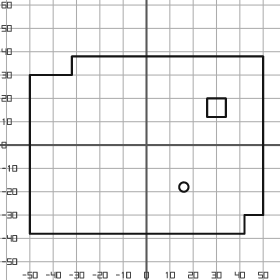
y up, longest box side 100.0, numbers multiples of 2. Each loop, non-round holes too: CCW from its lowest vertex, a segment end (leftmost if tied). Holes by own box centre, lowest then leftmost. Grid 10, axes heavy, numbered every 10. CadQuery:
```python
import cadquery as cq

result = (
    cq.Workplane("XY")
    .moveTo(-50.0, -38.0)
    .lineTo(42.0, -38.0)
    .lineTo(42.0, -30.0)
    .lineTo(50.0, -30.0)
    .lineTo(50.0, 38.0)
    .lineTo(-32.0, 38.0)
    .lineTo(-32.0, 30.0)
    .lineTo(-50.0, 30.0)
    .close()
    .moveTo(16.0, -18.0)
    .circle(2.0)
    .moveTo(26.0, 12.0)
    .lineTo(34.0, 12.0)
    .lineTo(34.0, 20.0)
    .lineTo(26.0, 20.0)
    .close()
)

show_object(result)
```